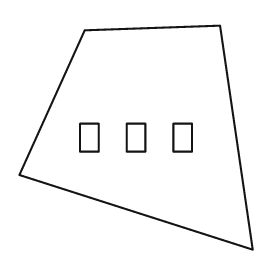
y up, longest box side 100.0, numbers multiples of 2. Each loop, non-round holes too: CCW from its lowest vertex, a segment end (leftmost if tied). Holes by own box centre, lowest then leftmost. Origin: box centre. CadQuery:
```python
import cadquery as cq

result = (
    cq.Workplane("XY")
    .moveTo(50.0, -48.0)
    .lineTo(36.0, 48.0)
    .lineTo(-22.0, 46.0)
    .lineTo(-50.0, -16.0)
    .close()
    .moveTo(-24.0, -6.0)
    .lineTo(-16.0, -6.0)
    .lineTo(-16.0, 6.0)
    .lineTo(-24.0, 6.0)
    .close()
    .moveTo(-4.0, -6.0)
    .lineTo(4.0, -6.0)
    .lineTo(4.0, 6.0)
    .lineTo(-4.0, 6.0)
    .close()
    .moveTo(16.0, -6.0)
    .lineTo(24.0, -6.0)
    .lineTo(24.0, 6.0)
    .lineTo(16.0, 6.0)
    .close()
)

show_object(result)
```